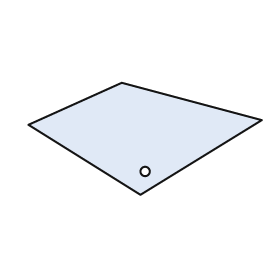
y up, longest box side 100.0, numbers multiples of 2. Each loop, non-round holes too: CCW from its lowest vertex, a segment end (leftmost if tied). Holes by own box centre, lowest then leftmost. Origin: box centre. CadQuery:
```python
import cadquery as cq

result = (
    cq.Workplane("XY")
    .moveTo(-2.0, -24.0)
    .lineTo(50.0, 8.0)
    .lineTo(-10.0, 24.0)
    .lineTo(-50.0, 6.0)
    .close()
    .moveTo(0.0, -14.0)
    .circle(2.0)
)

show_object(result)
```